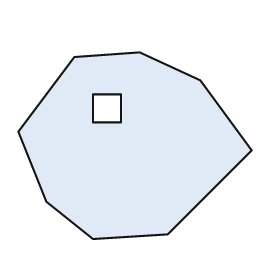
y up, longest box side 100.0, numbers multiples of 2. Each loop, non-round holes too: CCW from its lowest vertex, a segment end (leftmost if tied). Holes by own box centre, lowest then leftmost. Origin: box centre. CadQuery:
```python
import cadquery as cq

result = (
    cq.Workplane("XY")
    .moveTo(-18.0, -40.0)
    .lineTo(14.0, -38.0)
    .lineTo(50.0, -2.0)
    .lineTo(28.0, 28.0)
    .lineTo(2.0, 40.0)
    .lineTo(-26.0, 38.0)
    .lineTo(-50.0, 6.0)
    .lineTo(-38.0, -24.0)
    .close()
    .moveTo(-18.0, 10.0)
    .lineTo(-6.0, 10.0)
    .lineTo(-6.0, 22.0)
    .lineTo(-18.0, 22.0)
    .close()
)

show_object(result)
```